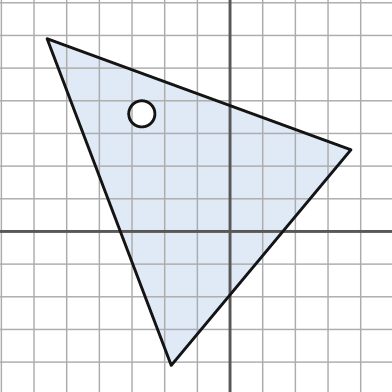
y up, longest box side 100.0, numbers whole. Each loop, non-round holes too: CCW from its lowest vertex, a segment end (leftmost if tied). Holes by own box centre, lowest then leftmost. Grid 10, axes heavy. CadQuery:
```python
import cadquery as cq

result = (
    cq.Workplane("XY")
    .moveTo(-18.0, -41.0)
    .lineTo(37.0, 25.0)
    .lineTo(-56.0, 59.0)
    .close()
    .moveTo(-27.0, 36.0)
    .circle(4.0)
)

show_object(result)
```